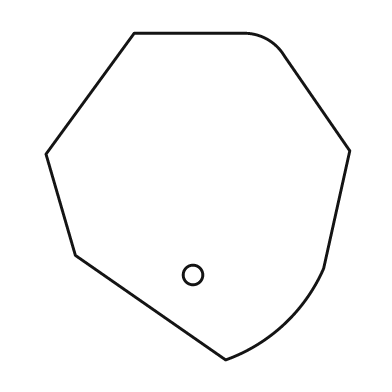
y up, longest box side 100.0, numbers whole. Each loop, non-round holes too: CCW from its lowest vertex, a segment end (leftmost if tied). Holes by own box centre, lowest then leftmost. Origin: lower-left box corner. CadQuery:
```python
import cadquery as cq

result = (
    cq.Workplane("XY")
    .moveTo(55.0, 0.0)
    .threePointArc((73.0, 11.0), (85.0, 28.0))
    .lineTo(93.0, 64.0)
    .lineTo(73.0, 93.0)
    .threePointArc((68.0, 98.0), (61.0, 100.0))
    .lineTo(27.0, 100.0)
    .lineTo(0.0, 63.0)
    .lineTo(9.0, 32.0)
    .close()
    .moveTo(45.0, 26.0)
    .circle(3.0)
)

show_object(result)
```